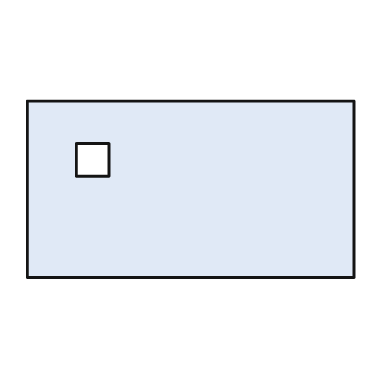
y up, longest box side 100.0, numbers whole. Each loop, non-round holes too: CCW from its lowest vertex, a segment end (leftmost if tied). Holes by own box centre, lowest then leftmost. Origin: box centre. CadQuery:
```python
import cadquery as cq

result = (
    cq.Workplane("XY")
    .moveTo(-50.0, -27.0)
    .lineTo(50.0, -27.0)
    .lineTo(50.0, 27.0)
    .lineTo(-50.0, 27.0)
    .close()
    .moveTo(-35.0, 4.0)
    .lineTo(-25.0, 4.0)
    .lineTo(-25.0, 14.0)
    .lineTo(-35.0, 14.0)
    .close()
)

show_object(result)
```